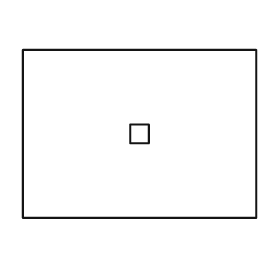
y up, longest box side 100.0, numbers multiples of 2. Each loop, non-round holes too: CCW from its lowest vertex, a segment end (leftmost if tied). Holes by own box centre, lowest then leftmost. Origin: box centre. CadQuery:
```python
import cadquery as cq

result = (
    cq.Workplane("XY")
    .moveTo(-50.0, -36.0)
    .lineTo(50.0, -36.0)
    .lineTo(50.0, 36.0)
    .lineTo(-50.0, 36.0)
    .close()
    .moveTo(-4.0, -4.0)
    .lineTo(4.0, -4.0)
    .lineTo(4.0, 4.0)
    .lineTo(-4.0, 4.0)
    .close()
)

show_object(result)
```